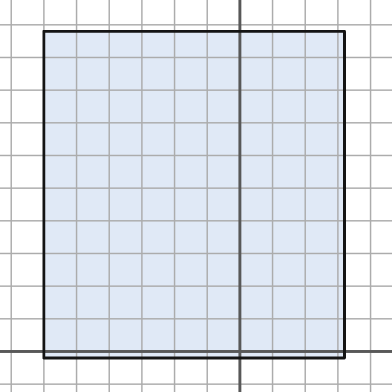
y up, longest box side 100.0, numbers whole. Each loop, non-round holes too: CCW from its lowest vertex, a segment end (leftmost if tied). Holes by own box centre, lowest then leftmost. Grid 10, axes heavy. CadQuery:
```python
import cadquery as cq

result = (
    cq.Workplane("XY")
    .moveTo(-60.0, -2.0)
    .lineTo(32.0, -2.0)
    .lineTo(32.0, 98.0)
    .lineTo(-60.0, 98.0)
    .close()
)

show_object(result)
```